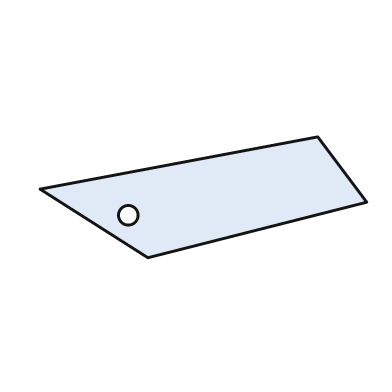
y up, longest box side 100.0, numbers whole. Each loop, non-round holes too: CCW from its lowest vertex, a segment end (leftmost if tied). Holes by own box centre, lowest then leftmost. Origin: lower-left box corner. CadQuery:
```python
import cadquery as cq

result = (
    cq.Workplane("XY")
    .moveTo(33.0, 0.0)
    .lineTo(100.0, 17.0)
    .lineTo(85.0, 37.0)
    .lineTo(0.0, 21.0)
    .close()
    .moveTo(27.0, 13.0)
    .circle(3.0)
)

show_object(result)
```